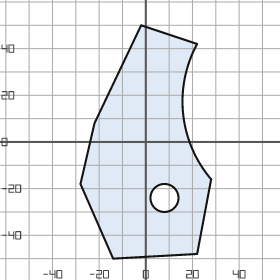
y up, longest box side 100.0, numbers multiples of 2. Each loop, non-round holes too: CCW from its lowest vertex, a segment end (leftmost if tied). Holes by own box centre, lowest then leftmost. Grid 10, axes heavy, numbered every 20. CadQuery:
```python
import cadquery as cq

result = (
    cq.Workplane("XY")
    .moveTo(-14.0, -50.0)
    .lineTo(22.0, -48.0)
    .lineTo(28.0, -16.0)
    .threePointArc((16.0, 12.0), (22.0, 42.0))
    .lineTo(-2.0, 50.0)
    .lineTo(-22.0, 8.0)
    .lineTo(-28.0, -18.0)
    .close()
    .moveTo(8.0, -24.0)
    .circle(6.0)
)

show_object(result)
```